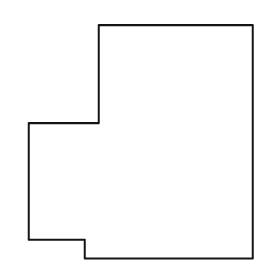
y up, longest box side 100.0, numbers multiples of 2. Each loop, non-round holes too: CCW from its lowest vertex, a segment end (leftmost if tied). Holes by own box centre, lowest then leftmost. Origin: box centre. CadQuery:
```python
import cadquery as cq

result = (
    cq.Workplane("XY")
    .moveTo(-24.0, -50.0)
    .lineTo(48.0, -50.0)
    .lineTo(48.0, 50.0)
    .lineTo(-18.0, 50.0)
    .lineTo(-18.0, 8.0)
    .lineTo(-48.0, 8.0)
    .lineTo(-48.0, -42.0)
    .lineTo(-24.0, -42.0)
    .close()
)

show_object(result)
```